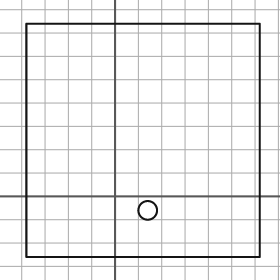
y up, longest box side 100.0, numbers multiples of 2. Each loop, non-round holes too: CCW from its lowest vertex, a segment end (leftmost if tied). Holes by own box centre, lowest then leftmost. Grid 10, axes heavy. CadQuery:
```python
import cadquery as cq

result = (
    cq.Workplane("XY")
    .moveTo(-38.0, -26.0)
    .lineTo(62.0, -26.0)
    .lineTo(62.0, 74.0)
    .lineTo(-38.0, 74.0)
    .close()
    .moveTo(14.0, -6.0)
    .circle(4.0)
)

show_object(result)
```